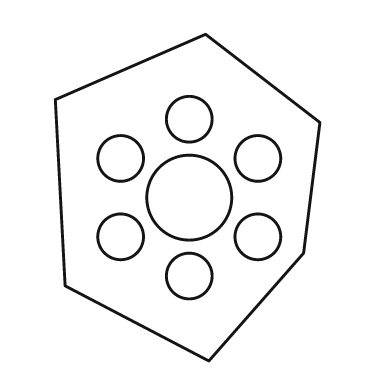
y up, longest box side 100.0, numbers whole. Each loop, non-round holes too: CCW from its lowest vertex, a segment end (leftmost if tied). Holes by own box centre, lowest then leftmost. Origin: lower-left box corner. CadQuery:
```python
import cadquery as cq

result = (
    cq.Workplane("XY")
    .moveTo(47.0, 0.0)
    .lineTo(76.0, 33.0)
    .lineTo(81.0, 73.0)
    .lineTo(46.0, 100.0)
    .lineTo(0.0, 80.0)
    .lineTo(3.0, 23.0)
    .close()
    .moveTo(41.0, 26.0)
    .circle(7.0)
    .moveTo(20.0, 38.0)
    .circle(7.0)
    .moveTo(62.0, 38.0)
    .circle(7.0)
    .moveTo(41.0, 50.0)
    .circle(13.0)
    .moveTo(20.0, 62.0)
    .circle(7.0)
    .moveTo(62.0, 62.0)
    .circle(7.0)
    .moveTo(41.0, 74.0)
    .circle(7.0)
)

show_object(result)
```